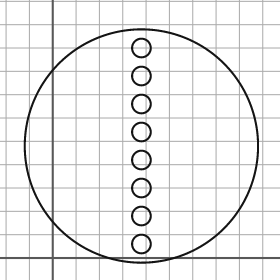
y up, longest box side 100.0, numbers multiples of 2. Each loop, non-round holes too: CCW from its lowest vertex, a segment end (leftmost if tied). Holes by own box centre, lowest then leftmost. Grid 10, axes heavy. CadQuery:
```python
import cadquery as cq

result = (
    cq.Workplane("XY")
    .moveTo(38.0, 48.0)
    .circle(50.0)
    .moveTo(38.0, 6.0)
    .circle(4.0)
    .moveTo(38.0, 18.0)
    .circle(4.0)
    .moveTo(38.0, 30.0)
    .circle(4.0)
    .moveTo(38.0, 42.0)
    .circle(4.0)
    .moveTo(38.0, 54.0)
    .circle(4.0)
    .moveTo(38.0, 66.0)
    .circle(4.0)
    .moveTo(38.0, 78.0)
    .circle(4.0)
    .moveTo(38.0, 90.0)
    .circle(4.0)
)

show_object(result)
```